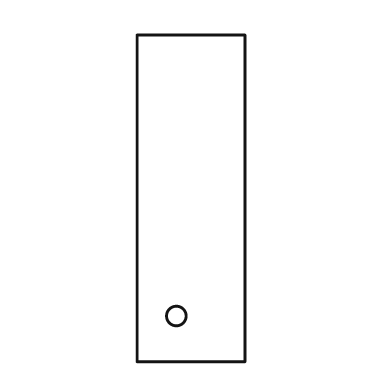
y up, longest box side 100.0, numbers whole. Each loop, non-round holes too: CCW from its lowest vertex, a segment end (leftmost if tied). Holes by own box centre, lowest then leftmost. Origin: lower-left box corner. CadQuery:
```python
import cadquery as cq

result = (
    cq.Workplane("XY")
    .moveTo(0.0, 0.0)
    .lineTo(33.0, 0.0)
    .lineTo(33.0, 100.0)
    .lineTo(0.0, 100.0)
    .close()
    .moveTo(12.0, 14.0)
    .circle(3.0)
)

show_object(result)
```